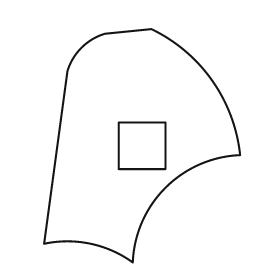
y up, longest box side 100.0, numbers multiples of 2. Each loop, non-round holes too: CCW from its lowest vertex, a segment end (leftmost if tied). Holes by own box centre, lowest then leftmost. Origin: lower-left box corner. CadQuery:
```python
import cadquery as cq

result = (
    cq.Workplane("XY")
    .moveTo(38.0, 0.0)
    .threePointArc((52.0, 32.0), (84.0, 46.0))
    .threePointArc((72.0, 78.0), (46.0, 100.0))
    .lineTo(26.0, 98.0)
    .threePointArc((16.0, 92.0), (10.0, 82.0))
    .lineTo(0.0, 8.0)
    .threePointArc((20.0, 8.0), (38.0, 0.0))
    .close()
    .moveTo(32.0, 40.0)
    .lineTo(52.0, 40.0)
    .lineTo(52.0, 60.0)
    .lineTo(32.0, 60.0)
    .close()
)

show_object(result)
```